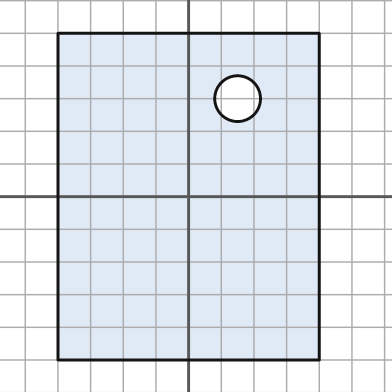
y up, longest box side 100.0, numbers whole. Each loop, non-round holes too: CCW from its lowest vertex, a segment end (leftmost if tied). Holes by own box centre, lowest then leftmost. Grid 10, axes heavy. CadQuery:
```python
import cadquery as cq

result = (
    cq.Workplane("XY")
    .moveTo(-40.0, -50.0)
    .lineTo(40.0, -50.0)
    .lineTo(40.0, 50.0)
    .lineTo(-40.0, 50.0)
    .close()
    .moveTo(15.0, 30.0)
    .circle(7.0)
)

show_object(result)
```